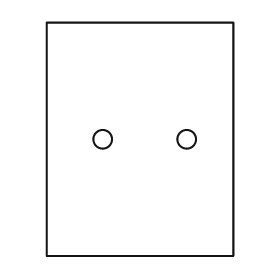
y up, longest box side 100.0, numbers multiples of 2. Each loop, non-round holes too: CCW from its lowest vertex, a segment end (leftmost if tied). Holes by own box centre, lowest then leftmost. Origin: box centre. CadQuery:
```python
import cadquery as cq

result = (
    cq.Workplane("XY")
    .moveTo(-40.0, -50.0)
    .lineTo(40.0, -50.0)
    .lineTo(40.0, 50.0)
    .lineTo(-40.0, 50.0)
    .close()
    .moveTo(-16.0, 0.0)
    .circle(4.0)
    .moveTo(20.0, 0.0)
    .circle(4.0)
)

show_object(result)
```